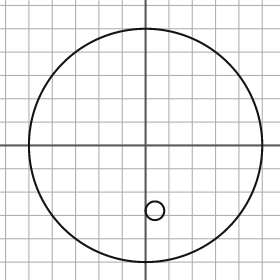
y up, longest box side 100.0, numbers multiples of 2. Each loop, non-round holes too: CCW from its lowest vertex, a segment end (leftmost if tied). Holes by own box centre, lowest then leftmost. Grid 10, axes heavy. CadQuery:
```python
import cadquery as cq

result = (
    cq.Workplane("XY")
    .moveTo(0.0, 0.0)
    .circle(50.0)
    .moveTo(4.0, -28.0)
    .circle(4.0)
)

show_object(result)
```